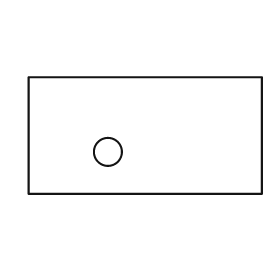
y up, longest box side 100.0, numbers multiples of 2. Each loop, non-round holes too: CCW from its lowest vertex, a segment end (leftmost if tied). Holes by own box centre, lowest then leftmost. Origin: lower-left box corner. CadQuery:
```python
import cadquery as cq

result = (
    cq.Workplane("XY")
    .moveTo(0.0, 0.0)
    .lineTo(100.0, 0.0)
    .lineTo(100.0, 50.0)
    .lineTo(0.0, 50.0)
    .close()
    .moveTo(34.0, 18.0)
    .circle(6.0)
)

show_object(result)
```